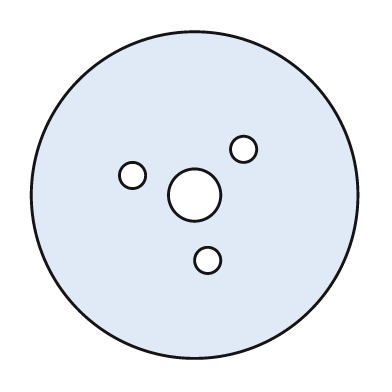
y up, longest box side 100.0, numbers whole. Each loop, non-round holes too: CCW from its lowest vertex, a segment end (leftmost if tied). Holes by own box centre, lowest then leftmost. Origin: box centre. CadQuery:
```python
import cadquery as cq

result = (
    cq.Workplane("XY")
    .moveTo(0.0, 0.0)
    .circle(50.0)
    .moveTo(4.0, -20.0)
    .circle(4.0)
    .moveTo(0.0, 0.0)
    .circle(8.0)
    .moveTo(-19.0, 6.0)
    .circle(4.0)
    .moveTo(15.0, 14.0)
    .circle(4.0)
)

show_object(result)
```